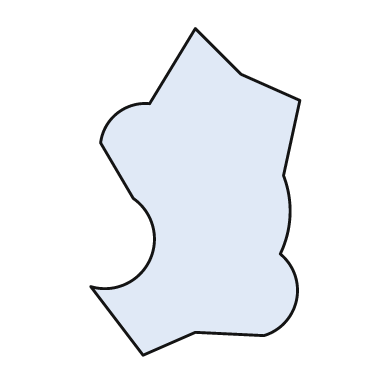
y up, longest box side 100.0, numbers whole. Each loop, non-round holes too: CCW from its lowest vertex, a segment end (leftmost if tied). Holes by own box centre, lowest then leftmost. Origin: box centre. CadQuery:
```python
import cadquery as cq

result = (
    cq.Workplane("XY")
    .moveTo(-16.0, -50.0)
    .lineTo(0.0, -43.0)
    .lineTo(21.0, -44.0)
    .threePointArc((31.0, -33.0), (26.0, -19.0))
    .threePointArc((29.0, -7.0), (27.0, 5.0))
    .lineTo(32.0, 28.0)
    .lineTo(14.0, 36.0)
    .lineTo(0.0, 50.0)
    .lineTo(-14.0, 27.0)
    .threePointArc((-24.0, 24.0), (-29.0, 15.0))
    .lineTo(-19.0, -2.0)
    .threePointArc((-14.0, -21.0), (-32.0, -29.0))
    .close()
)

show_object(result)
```